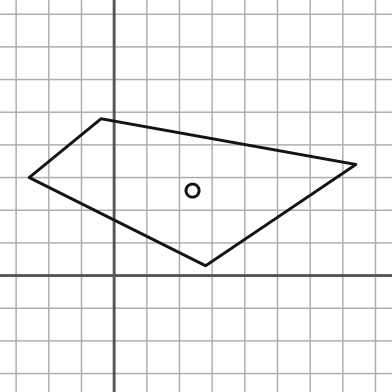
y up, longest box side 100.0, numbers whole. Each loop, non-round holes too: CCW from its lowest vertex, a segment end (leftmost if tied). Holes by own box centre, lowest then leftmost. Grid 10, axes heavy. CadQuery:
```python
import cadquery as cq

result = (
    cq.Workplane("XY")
    .moveTo(28.0, 3.0)
    .lineTo(74.0, 34.0)
    .lineTo(-4.0, 48.0)
    .lineTo(-26.0, 30.0)
    .close()
    .moveTo(24.0, 26.0)
    .circle(2.0)
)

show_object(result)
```